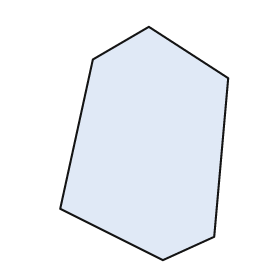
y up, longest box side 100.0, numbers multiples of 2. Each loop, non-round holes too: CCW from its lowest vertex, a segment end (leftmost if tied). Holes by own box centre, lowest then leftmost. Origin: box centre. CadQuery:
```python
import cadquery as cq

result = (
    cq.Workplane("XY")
    .moveTo(8.0, -50.0)
    .lineTo(30.0, -40.0)
    .lineTo(36.0, 28.0)
    .lineTo(2.0, 50.0)
    .lineTo(-22.0, 36.0)
    .lineTo(-36.0, -28.0)
    .close()
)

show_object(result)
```